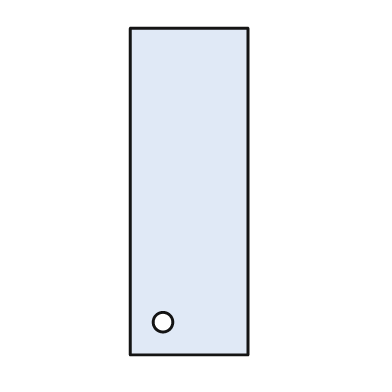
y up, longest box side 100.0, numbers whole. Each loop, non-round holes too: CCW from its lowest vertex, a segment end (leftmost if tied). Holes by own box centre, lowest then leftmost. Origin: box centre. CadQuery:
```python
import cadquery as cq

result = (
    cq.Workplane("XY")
    .moveTo(-18.0, -50.0)
    .lineTo(18.0, -50.0)
    .lineTo(18.0, 50.0)
    .lineTo(-18.0, 50.0)
    .close()
    .moveTo(-8.0, -40.0)
    .circle(3.0)
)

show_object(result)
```